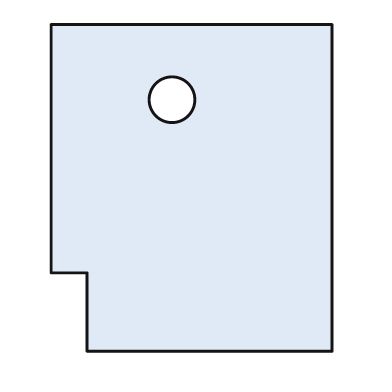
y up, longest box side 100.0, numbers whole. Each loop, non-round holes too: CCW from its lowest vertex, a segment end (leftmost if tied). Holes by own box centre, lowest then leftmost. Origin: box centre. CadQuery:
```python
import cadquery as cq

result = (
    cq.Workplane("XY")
    .moveTo(-32.0, -50.0)
    .lineTo(43.0, -50.0)
    .lineTo(43.0, 50.0)
    .lineTo(-43.0, 50.0)
    .lineTo(-43.0, -26.0)
    .lineTo(-32.0, -26.0)
    .close()
    .moveTo(-6.0, 27.0)
    .circle(7.0)
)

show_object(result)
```